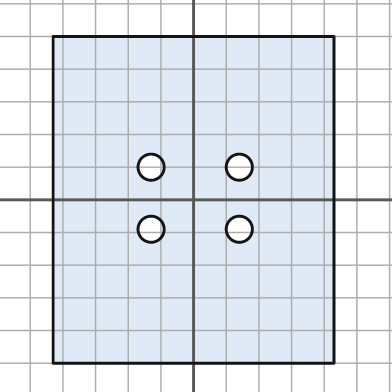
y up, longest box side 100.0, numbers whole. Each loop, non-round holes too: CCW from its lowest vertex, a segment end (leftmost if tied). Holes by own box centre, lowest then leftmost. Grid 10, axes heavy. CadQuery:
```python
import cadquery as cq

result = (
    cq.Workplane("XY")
    .moveTo(-43.0, -50.0)
    .lineTo(43.0, -50.0)
    .lineTo(43.0, 50.0)
    .lineTo(-43.0, 50.0)
    .close()
    .moveTo(-13.0, -9.0)
    .circle(4.0)
    .moveTo(14.0, -9.0)
    .circle(4.0)
    .moveTo(-13.0, 10.0)
    .circle(4.0)
    .moveTo(14.0, 10.0)
    .circle(4.0)
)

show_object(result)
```